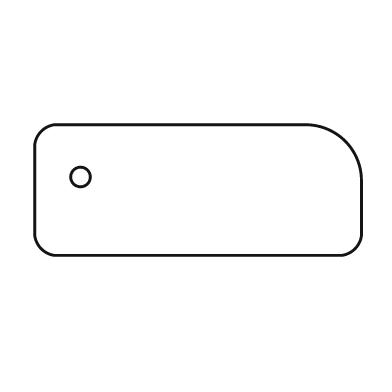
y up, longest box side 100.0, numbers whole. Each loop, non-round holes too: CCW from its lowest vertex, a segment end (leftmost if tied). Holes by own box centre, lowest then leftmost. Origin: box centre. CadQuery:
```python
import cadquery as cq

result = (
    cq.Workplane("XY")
    .moveTo(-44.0, -20.0)
    .lineTo(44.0, -20.0)
    .threePointArc((48.0, -18.0), (50.0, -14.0))
    .lineTo(50.0, 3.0)
    .threePointArc((45.0, 15.0), (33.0, 20.0))
    .lineTo(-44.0, 20.0)
    .threePointArc((-48.0, 18.0), (-50.0, 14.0))
    .lineTo(-50.0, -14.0)
    .threePointArc((-48.0, -18.0), (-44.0, -20.0))
    .close()
    .moveTo(-36.0, 4.0)
    .circle(3.0)
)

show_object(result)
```